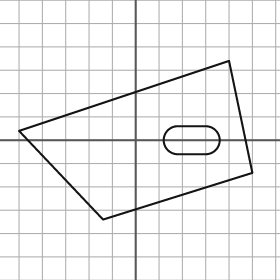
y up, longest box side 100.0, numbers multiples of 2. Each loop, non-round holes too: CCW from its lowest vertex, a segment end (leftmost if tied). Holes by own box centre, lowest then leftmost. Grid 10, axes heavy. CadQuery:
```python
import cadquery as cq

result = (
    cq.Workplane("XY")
    .moveTo(-14.0, -34.0)
    .lineTo(50.0, -14.0)
    .lineTo(40.0, 34.0)
    .lineTo(-50.0, 4.0)
    .close()
    .moveTo(18.0, -6.0)
    .lineTo(30.0, -6.0)
    .threePointArc((36.0, 0.0), (30.0, 6.0))
    .lineTo(18.0, 6.0)
    .threePointArc((12.0, 0.0), (18.0, -6.0))
    .close()
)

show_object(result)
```